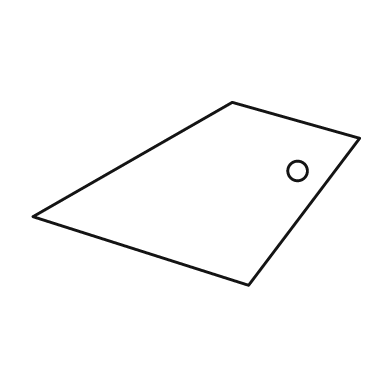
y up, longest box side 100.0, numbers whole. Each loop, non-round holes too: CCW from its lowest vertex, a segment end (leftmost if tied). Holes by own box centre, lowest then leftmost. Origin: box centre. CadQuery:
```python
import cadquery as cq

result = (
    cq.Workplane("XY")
    .moveTo(16.0, -28.0)
    .lineTo(50.0, 17.0)
    .lineTo(11.0, 28.0)
    .lineTo(-50.0, -7.0)
    .close()
    .moveTo(31.0, 7.0)
    .circle(3.0)
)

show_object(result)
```